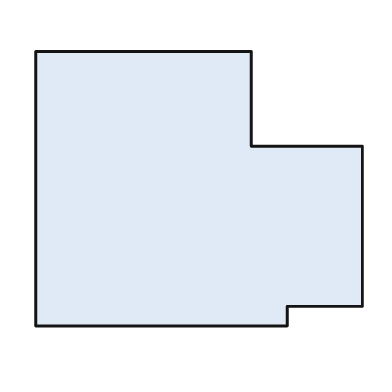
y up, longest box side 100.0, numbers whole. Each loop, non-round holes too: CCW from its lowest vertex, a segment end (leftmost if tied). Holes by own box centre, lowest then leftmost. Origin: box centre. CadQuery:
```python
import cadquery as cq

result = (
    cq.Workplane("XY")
    .moveTo(-50.0, -42.0)
    .lineTo(27.0, -42.0)
    .lineTo(27.0, -36.0)
    .lineTo(50.0, -36.0)
    .lineTo(50.0, 13.0)
    .lineTo(16.0, 13.0)
    .lineTo(16.0, 42.0)
    .lineTo(-50.0, 42.0)
    .close()
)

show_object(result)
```